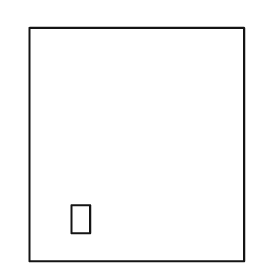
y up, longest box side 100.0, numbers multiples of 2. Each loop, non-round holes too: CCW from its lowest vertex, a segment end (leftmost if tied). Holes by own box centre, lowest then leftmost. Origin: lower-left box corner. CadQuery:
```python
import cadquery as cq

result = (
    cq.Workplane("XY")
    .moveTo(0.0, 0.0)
    .lineTo(92.0, 0.0)
    .lineTo(92.0, 100.0)
    .lineTo(0.0, 100.0)
    .close()
    .moveTo(18.0, 12.0)
    .lineTo(26.0, 12.0)
    .lineTo(26.0, 24.0)
    .lineTo(18.0, 24.0)
    .close()
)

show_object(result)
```